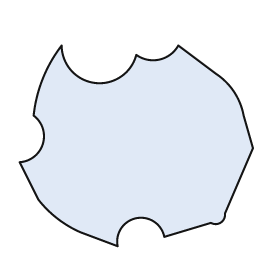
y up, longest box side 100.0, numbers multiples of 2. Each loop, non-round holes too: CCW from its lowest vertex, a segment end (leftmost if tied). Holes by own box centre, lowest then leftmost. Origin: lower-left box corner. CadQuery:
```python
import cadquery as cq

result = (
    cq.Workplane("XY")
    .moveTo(42.0, 0.0)
    .threePointArc((50.0, 12.0), (62.0, 4.0))
    .lineTo(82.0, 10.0)
    .threePointArc((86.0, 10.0), (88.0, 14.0))
    .lineTo(100.0, 42.0)
    .lineTo(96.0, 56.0)
    .threePointArc((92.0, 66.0), (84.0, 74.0))
    .lineTo(68.0, 86.0)
    .threePointArc((60.0, 80.0), (50.0, 82.0))
    .threePointArc((32.0, 70.0), (18.0, 86.0))
    .threePointArc((10.0, 72.0), (6.0, 56.0))
    .threePointArc((10.0, 44.0), (0.0, 36.0))
    .lineTo(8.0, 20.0)
    .threePointArc((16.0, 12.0), (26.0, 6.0))
    .close()
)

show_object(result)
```